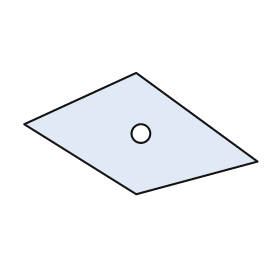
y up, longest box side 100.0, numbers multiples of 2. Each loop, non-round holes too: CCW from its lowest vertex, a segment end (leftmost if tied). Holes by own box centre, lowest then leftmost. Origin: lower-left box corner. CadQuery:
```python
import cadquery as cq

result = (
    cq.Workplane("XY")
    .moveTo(48.0, 0.0)
    .lineTo(100.0, 14.0)
    .lineTo(48.0, 52.0)
    .lineTo(0.0, 30.0)
    .close()
    .moveTo(50.0, 26.0)
    .circle(4.0)
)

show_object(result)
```